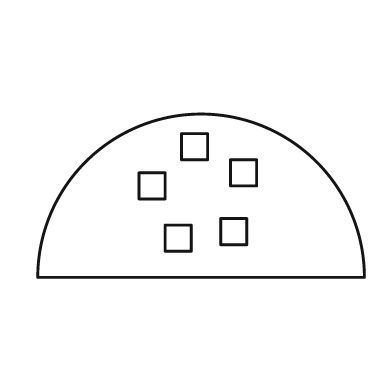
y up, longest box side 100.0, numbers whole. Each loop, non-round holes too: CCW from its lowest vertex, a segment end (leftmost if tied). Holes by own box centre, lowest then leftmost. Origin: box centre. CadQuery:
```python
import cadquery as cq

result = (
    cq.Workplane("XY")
    .moveTo(-50.0, -25.0)
    .lineTo(50.0, -25.0)
    .threePointArc((0.0, 25.0), (-50.0, -25.0))
    .close()
    .moveTo(-11.0, -17.0)
    .lineTo(-3.0, -17.0)
    .lineTo(-3.0, -9.0)
    .lineTo(-11.0, -9.0)
    .close()
    .moveTo(6.0, -15.0)
    .lineTo(14.0, -15.0)
    .lineTo(14.0, -7.0)
    .lineTo(6.0, -7.0)
    .close()
    .moveTo(-19.0, -1.0)
    .lineTo(-11.0, -1.0)
    .lineTo(-11.0, 7.0)
    .lineTo(-19.0, 7.0)
    .close()
    .moveTo(9.0, 3.0)
    .lineTo(17.0, 3.0)
    .lineTo(17.0, 11.0)
    .lineTo(9.0, 11.0)
    .close()
    .moveTo(-6.0, 11.0)
    .lineTo(2.0, 11.0)
    .lineTo(2.0, 19.0)
    .lineTo(-6.0, 19.0)
    .close()
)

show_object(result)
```